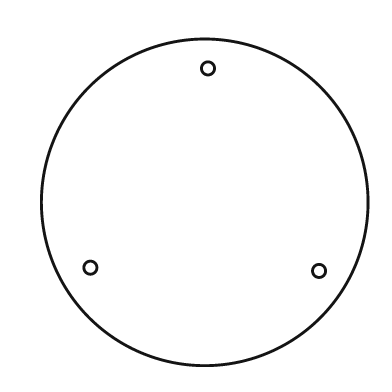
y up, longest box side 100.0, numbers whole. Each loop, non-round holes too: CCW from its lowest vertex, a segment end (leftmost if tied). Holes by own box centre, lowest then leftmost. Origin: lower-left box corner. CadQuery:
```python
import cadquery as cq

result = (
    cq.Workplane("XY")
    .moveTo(50.0, 50.0)
    .circle(50.0)
    .moveTo(85.0, 29.0)
    .circle(2.0)
    .moveTo(15.0, 30.0)
    .circle(2.0)
    .moveTo(51.0, 91.0)
    .circle(2.0)
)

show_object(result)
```